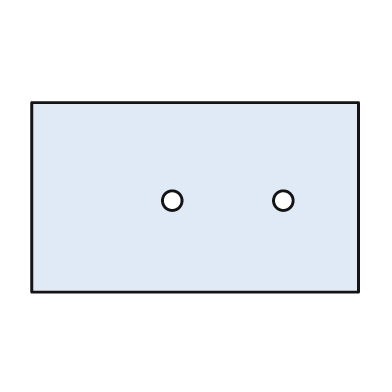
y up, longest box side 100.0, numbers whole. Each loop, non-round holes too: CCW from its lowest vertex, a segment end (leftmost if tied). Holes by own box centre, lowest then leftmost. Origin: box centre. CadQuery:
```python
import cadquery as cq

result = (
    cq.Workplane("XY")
    .moveTo(-50.0, -29.0)
    .lineTo(50.0, -29.0)
    .lineTo(50.0, 29.0)
    .lineTo(-50.0, 29.0)
    .close()
    .moveTo(-7.0, -1.0)
    .circle(3.0)
    .moveTo(27.0, -1.0)
    .circle(3.0)
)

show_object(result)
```